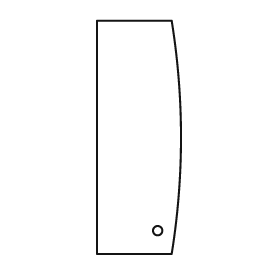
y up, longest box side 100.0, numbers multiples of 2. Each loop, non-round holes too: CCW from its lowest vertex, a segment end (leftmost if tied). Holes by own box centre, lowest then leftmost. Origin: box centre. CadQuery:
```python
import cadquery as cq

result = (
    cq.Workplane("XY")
    .moveTo(-18.0, -50.0)
    .lineTo(14.0, -50.0)
    .threePointArc((18.0, 0.0), (14.0, 50.0))
    .lineTo(-18.0, 50.0)
    .close()
    .moveTo(8.0, -40.0)
    .circle(2.0)
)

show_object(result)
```